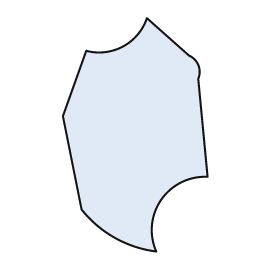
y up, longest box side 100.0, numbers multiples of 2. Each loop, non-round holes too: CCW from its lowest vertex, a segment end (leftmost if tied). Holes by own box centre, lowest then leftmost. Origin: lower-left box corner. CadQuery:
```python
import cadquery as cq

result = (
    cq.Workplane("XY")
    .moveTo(40.0, 0.0)
    .threePointArc((42.0, 22.0), (62.0, 32.0))
    .lineTo(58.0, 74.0)
    .threePointArc((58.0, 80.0), (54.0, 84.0))
    .lineTo(36.0, 100.0)
    .threePointArc((26.0, 88.0), (10.0, 86.0))
    .lineTo(0.0, 58.0)
    .lineTo(8.0, 18.0)
    .threePointArc((22.0, 6.0), (40.0, 0.0))
    .close()
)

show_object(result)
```